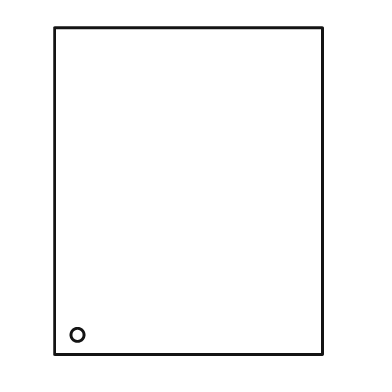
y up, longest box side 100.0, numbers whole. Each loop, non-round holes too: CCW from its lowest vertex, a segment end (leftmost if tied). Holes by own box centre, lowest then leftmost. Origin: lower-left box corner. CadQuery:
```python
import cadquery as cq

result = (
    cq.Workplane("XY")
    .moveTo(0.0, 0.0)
    .lineTo(82.0, 0.0)
    .lineTo(82.0, 100.0)
    .lineTo(0.0, 100.0)
    .close()
    .moveTo(7.0, 6.0)
    .circle(2.0)
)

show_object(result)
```